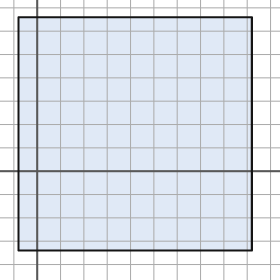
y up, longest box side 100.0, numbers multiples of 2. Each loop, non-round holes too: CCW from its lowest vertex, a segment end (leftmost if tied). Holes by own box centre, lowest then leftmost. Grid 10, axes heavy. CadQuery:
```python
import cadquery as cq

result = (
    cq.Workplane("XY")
    .moveTo(-8.0, -34.0)
    .lineTo(92.0, -34.0)
    .lineTo(92.0, 66.0)
    .lineTo(-8.0, 66.0)
    .close()
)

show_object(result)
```